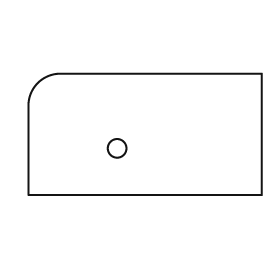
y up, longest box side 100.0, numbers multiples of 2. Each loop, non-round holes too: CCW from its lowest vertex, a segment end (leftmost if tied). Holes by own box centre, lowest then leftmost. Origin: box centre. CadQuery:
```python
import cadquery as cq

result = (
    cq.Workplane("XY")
    .moveTo(-50.0, -26.0)
    .lineTo(50.0, -26.0)
    .lineTo(50.0, 26.0)
    .lineTo(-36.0, 26.0)
    .threePointArc((-46.0, 22.0), (-50.0, 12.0))
    .close()
    .moveTo(-12.0, -6.0)
    .circle(4.0)
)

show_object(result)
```